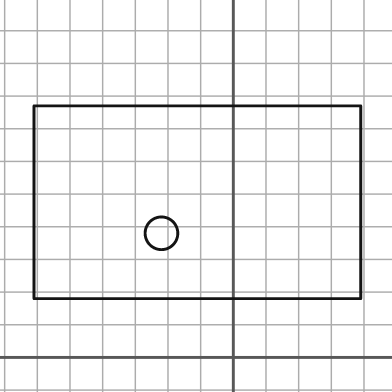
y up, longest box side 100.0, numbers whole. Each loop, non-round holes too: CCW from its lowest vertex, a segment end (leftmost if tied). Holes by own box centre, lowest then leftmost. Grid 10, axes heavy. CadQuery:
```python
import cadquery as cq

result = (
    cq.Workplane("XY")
    .moveTo(-61.0, 18.0)
    .lineTo(39.0, 18.0)
    .lineTo(39.0, 77.0)
    .lineTo(-61.0, 77.0)
    .close()
    .moveTo(-22.0, 38.0)
    .circle(5.0)
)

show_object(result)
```